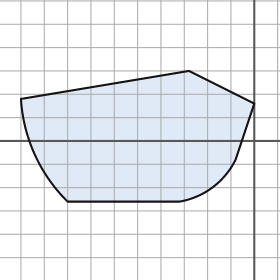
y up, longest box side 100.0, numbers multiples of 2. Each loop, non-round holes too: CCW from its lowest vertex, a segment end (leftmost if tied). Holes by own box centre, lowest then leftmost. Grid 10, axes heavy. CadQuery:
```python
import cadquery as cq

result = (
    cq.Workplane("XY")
    .moveTo(-80.0, -26.0)
    .lineTo(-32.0, -26.0)
    .threePointArc((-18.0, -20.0), (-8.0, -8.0))
    .lineTo(0.0, 16.0)
    .lineTo(-28.0, 30.0)
    .lineTo(-100.0, 18.0)
    .threePointArc((-94.0, -6.0), (-80.0, -26.0))
    .close()
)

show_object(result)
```